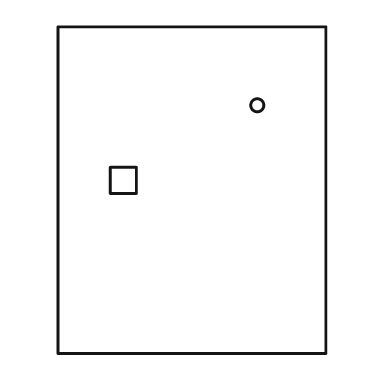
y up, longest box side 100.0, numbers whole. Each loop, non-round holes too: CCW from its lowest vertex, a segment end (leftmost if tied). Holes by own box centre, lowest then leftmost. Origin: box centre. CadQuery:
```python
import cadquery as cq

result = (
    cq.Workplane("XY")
    .moveTo(-41.0, -50.0)
    .lineTo(41.0, -50.0)
    .lineTo(41.0, 50.0)
    .lineTo(-41.0, 50.0)
    .close()
    .moveTo(-25.0, -1.0)
    .lineTo(-17.0, -1.0)
    .lineTo(-17.0, 7.0)
    .lineTo(-25.0, 7.0)
    .close()
    .moveTo(20.0, 26.0)
    .circle(2.0)
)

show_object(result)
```